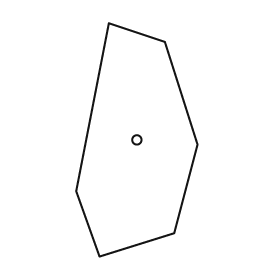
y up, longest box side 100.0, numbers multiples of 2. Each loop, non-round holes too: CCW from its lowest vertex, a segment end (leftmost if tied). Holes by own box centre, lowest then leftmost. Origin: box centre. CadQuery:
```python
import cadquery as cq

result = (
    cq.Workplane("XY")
    .moveTo(-16.0, -50.0)
    .lineTo(16.0, -40.0)
    .lineTo(26.0, -2.0)
    .lineTo(12.0, 42.0)
    .lineTo(-12.0, 50.0)
    .lineTo(-26.0, -22.0)
    .close()
    .moveTo(0.0, 0.0)
    .circle(2.0)
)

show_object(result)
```